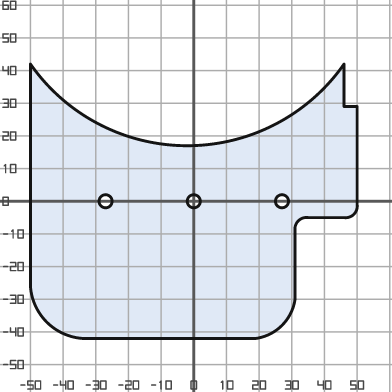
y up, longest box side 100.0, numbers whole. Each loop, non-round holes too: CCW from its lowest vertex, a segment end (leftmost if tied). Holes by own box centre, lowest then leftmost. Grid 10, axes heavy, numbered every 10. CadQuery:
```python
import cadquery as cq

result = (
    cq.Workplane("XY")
    .moveTo(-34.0, -42.0)
    .lineTo(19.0, -42.0)
    .threePointArc((27.0, -38.0), (31.0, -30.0))
    .lineTo(31.0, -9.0)
    .threePointArc((32.0, -6.0), (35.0, -5.0))
    .lineTo(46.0, -5.0)
    .threePointArc((49.0, -4.0), (50.0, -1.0))
    .lineTo(50.0, 29.0)
    .lineTo(46.0, 29.0)
    .lineTo(46.0, 42.0)
    .threePointArc((-2.0, 17.0), (-50.0, 42.0))
    .lineTo(-50.0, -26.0)
    .threePointArc((-45.0, -37.0), (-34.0, -42.0))
    .close()
    .moveTo(-27.0, 0.0)
    .circle(2.0)
    .moveTo(0.0, 0.0)
    .circle(2.0)
    .moveTo(27.0, 0.0)
    .circle(2.0)
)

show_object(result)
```